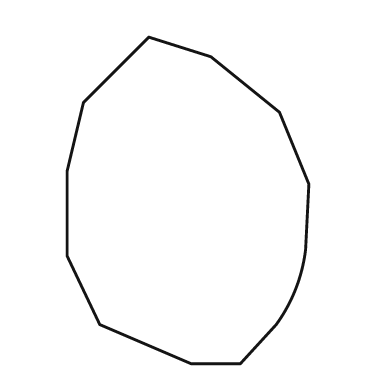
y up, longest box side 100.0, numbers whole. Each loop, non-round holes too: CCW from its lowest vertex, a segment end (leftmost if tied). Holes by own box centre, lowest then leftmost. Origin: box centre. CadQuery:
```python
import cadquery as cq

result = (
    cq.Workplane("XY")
    .moveTo(1.0, -50.0)
    .lineTo(16.0, -50.0)
    .lineTo(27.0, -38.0)
    .threePointArc((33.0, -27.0), (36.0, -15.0))
    .lineTo(37.0, 5.0)
    .lineTo(28.0, 27.0)
    .lineTo(7.0, 44.0)
    .lineTo(-12.0, 50.0)
    .lineTo(-32.0, 30.0)
    .lineTo(-37.0, 9.0)
    .lineTo(-37.0, -17.0)
    .lineTo(-27.0, -38.0)
    .close()
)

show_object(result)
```